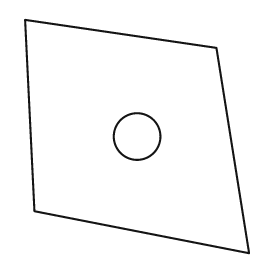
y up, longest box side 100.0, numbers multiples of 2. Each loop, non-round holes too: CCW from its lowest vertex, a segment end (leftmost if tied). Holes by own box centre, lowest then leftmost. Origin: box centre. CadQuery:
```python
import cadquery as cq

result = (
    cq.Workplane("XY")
    .moveTo(48.0, -50.0)
    .lineTo(34.0, 38.0)
    .lineTo(-48.0, 50.0)
    .lineTo(-44.0, -32.0)
    .close()
    .moveTo(0.0, 0.0)
    .circle(10.0)
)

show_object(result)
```